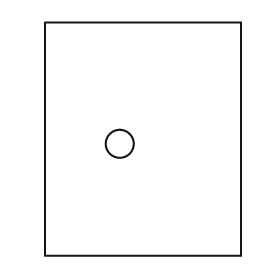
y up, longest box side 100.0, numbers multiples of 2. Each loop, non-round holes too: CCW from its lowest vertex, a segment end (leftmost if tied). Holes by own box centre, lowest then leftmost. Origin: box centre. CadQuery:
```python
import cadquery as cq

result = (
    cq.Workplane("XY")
    .moveTo(-42.0, -50.0)
    .lineTo(42.0, -50.0)
    .lineTo(42.0, 50.0)
    .lineTo(-42.0, 50.0)
    .close()
    .moveTo(-10.0, -2.0)
    .circle(6.0)
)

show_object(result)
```